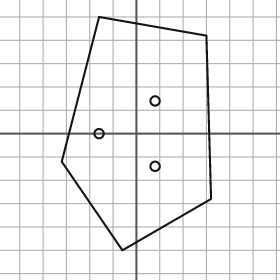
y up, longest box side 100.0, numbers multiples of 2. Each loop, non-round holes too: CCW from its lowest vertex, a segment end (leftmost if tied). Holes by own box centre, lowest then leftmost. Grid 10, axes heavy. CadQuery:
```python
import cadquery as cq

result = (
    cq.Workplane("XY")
    .moveTo(-6.0, -50.0)
    .lineTo(32.0, -28.0)
    .lineTo(30.0, 42.0)
    .lineTo(-16.0, 50.0)
    .lineTo(-32.0, -12.0)
    .close()
    .moveTo(8.0, -14.0)
    .circle(2.0)
    .moveTo(-16.0, 0.0)
    .circle(2.0)
    .moveTo(8.0, 14.0)
    .circle(2.0)
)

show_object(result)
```